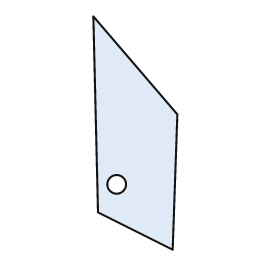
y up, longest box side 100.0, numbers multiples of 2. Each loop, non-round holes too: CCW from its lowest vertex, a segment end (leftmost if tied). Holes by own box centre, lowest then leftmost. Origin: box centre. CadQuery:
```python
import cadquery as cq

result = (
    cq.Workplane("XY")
    .moveTo(16.0, -50.0)
    .lineTo(18.0, 8.0)
    .lineTo(-18.0, 50.0)
    .lineTo(-16.0, -34.0)
    .close()
    .moveTo(-8.0, -22.0)
    .circle(4.0)
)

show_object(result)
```